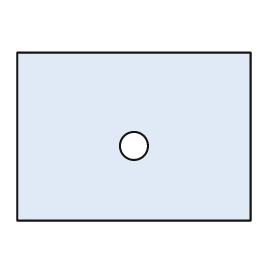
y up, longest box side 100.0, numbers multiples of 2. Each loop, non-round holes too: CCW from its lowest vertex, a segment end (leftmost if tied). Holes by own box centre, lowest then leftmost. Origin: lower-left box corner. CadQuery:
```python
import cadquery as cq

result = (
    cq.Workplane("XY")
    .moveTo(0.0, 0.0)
    .lineTo(100.0, 0.0)
    .lineTo(100.0, 72.0)
    .lineTo(0.0, 72.0)
    .close()
    .moveTo(50.0, 32.0)
    .circle(6.0)
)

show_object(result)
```